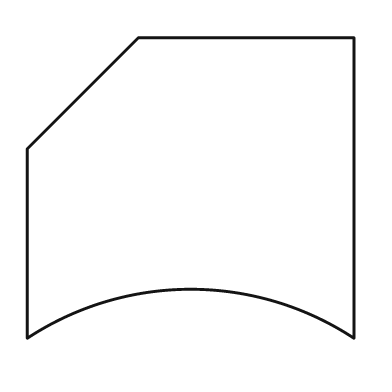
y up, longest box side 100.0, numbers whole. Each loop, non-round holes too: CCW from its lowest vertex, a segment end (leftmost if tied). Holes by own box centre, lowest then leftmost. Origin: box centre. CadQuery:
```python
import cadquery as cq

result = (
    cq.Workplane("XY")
    .moveTo(-50.0, -46.0)
    .threePointArc((0.0, -31.0), (50.0, -46.0))
    .lineTo(50.0, 46.0)
    .lineTo(-16.0, 46.0)
    .lineTo(-50.0, 12.0)
    .close()
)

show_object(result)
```